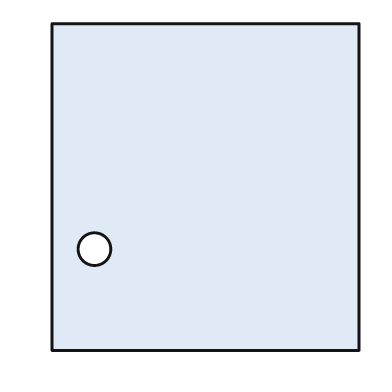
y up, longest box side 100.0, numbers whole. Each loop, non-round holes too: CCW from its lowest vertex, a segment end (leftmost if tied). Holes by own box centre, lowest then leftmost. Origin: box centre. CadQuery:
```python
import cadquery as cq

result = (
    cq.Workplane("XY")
    .moveTo(-47.0, -50.0)
    .lineTo(47.0, -50.0)
    .lineTo(47.0, 50.0)
    .lineTo(-47.0, 50.0)
    .close()
    .moveTo(-34.0, -19.0)
    .circle(5.0)
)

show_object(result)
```